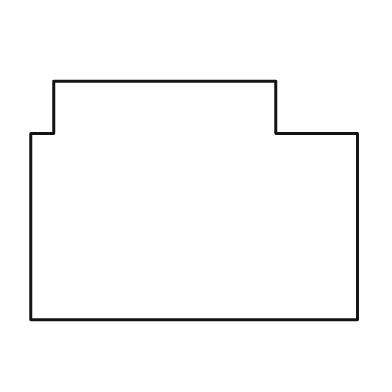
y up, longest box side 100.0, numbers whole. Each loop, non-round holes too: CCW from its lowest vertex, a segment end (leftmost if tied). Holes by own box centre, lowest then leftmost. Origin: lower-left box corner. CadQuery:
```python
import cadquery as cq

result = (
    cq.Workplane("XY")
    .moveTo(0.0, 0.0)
    .lineTo(100.0, 0.0)
    .lineTo(100.0, 57.0)
    .lineTo(75.0, 57.0)
    .lineTo(75.0, 73.0)
    .lineTo(7.0, 73.0)
    .lineTo(7.0, 57.0)
    .lineTo(0.0, 57.0)
    .close()
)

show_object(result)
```